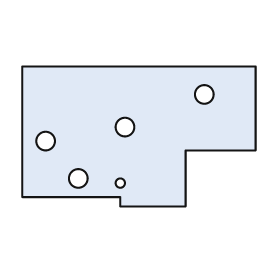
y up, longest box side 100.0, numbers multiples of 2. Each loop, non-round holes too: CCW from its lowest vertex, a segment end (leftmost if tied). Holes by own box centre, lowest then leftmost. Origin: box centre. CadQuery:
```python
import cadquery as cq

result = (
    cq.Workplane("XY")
    .moveTo(-8.0, -30.0)
    .lineTo(20.0, -30.0)
    .lineTo(20.0, -6.0)
    .lineTo(50.0, -6.0)
    .lineTo(50.0, 30.0)
    .lineTo(-50.0, 30.0)
    .lineTo(-50.0, -26.0)
    .lineTo(-8.0, -26.0)
    .close()
    .moveTo(-8.0, -20.0)
    .circle(2.0)
    .moveTo(-26.0, -18.0)
    .circle(4.0)
    .moveTo(-40.0, -2.0)
    .circle(4.0)
    .moveTo(-6.0, 4.0)
    .circle(4.0)
    .moveTo(28.0, 18.0)
    .circle(4.0)
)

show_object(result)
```